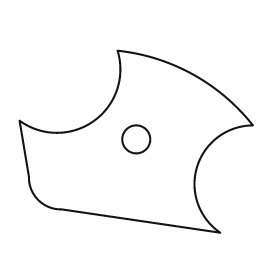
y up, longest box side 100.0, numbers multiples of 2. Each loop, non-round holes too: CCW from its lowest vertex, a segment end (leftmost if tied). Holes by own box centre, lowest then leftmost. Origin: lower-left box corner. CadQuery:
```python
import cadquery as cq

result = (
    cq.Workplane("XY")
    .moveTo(86.0, 0.0)
    .threePointArc((76.0, 28.0), (100.0, 46.0))
    .threePointArc((74.0, 68.0), (42.0, 78.0))
    .threePointArc((32.0, 48.0), (0.0, 48.0))
    .lineTo(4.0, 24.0)
    .threePointArc((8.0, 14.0), (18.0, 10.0))
    .close()
    .moveTo(50.0, 40.0)
    .circle(6.0)
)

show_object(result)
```